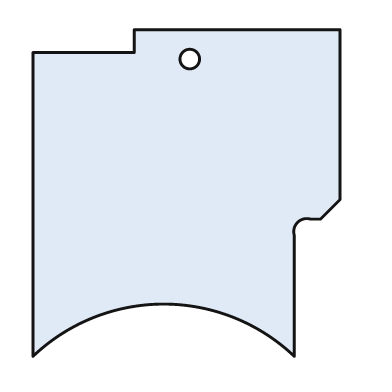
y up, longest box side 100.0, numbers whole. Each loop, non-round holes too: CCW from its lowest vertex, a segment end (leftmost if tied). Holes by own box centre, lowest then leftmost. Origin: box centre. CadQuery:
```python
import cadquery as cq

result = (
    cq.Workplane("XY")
    .moveTo(-47.0, -50.0)
    .threePointArc((-7.0, -34.0), (33.0, -50.0))
    .lineTo(33.0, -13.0)
    .threePointArc((34.0, -9.0), (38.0, -8.0))
    .lineTo(41.0, -8.0)
    .lineTo(47.0, -2.0)
    .lineTo(47.0, 50.0)
    .lineTo(-16.0, 50.0)
    .lineTo(-16.0, 43.0)
    .lineTo(-47.0, 43.0)
    .close()
    .moveTo(1.0, 41.0)
    .circle(3.0)
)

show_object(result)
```